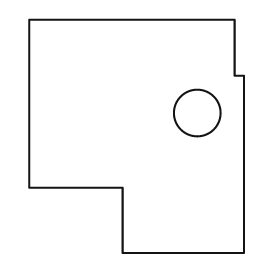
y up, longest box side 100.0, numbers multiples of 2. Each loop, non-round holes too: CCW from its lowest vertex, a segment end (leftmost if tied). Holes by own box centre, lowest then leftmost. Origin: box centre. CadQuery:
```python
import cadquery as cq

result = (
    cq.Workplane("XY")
    .moveTo(-6.0, -50.0)
    .lineTo(46.0, -50.0)
    .lineTo(46.0, 26.0)
    .lineTo(42.0, 26.0)
    .lineTo(42.0, 50.0)
    .lineTo(-46.0, 50.0)
    .lineTo(-46.0, -22.0)
    .lineTo(-6.0, -22.0)
    .close()
    .moveTo(26.0, 10.0)
    .circle(10.0)
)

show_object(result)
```